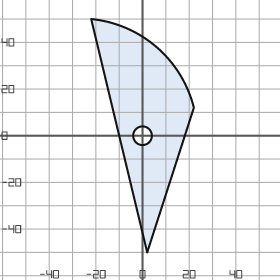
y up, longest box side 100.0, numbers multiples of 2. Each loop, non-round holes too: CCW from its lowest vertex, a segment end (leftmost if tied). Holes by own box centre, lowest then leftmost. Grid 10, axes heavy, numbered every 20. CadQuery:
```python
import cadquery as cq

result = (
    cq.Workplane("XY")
    .moveTo(2.0, -50.0)
    .lineTo(22.0, 12.0)
    .threePointArc((6.0, 38.0), (-22.0, 50.0))
    .close()
    .moveTo(0.0, 0.0)
    .circle(4.0)
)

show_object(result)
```